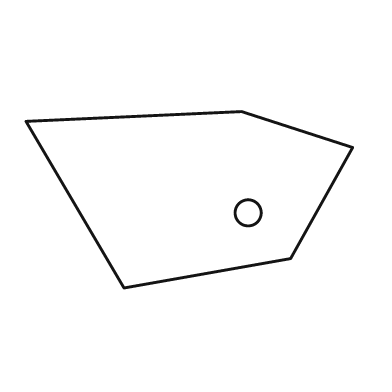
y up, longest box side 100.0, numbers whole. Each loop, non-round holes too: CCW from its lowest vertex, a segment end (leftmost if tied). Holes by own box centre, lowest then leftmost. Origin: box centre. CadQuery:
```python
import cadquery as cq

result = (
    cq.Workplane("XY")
    .moveTo(-20.0, -27.0)
    .lineTo(31.0, -18.0)
    .lineTo(50.0, 16.0)
    .lineTo(16.0, 27.0)
    .lineTo(-50.0, 24.0)
    .close()
    .moveTo(18.0, -4.0)
    .circle(4.0)
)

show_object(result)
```